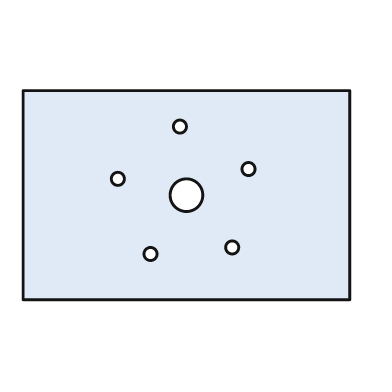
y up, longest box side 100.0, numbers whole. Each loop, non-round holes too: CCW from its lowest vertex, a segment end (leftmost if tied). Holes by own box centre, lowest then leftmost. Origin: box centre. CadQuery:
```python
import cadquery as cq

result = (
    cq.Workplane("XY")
    .moveTo(-50.0, -32.0)
    .lineTo(50.0, -32.0)
    .lineTo(50.0, 32.0)
    .lineTo(-50.0, 32.0)
    .close()
    .moveTo(-11.0, -18.0)
    .circle(2.0)
    .moveTo(14.0, -16.0)
    .circle(2.0)
    .moveTo(0.0, 0.0)
    .circle(5.0)
    .moveTo(-21.0, 5.0)
    .circle(2.0)
    .moveTo(19.0, 8.0)
    .circle(2.0)
    .moveTo(-2.0, 21.0)
    .circle(2.0)
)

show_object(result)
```